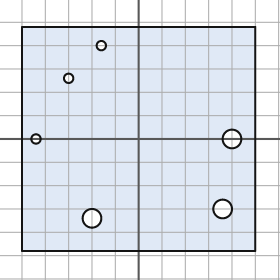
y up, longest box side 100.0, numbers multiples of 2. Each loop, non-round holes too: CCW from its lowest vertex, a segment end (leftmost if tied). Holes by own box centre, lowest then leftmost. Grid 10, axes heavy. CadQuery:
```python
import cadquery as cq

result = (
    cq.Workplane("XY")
    .moveTo(-50.0, -48.0)
    .lineTo(50.0, -48.0)
    .lineTo(50.0, 48.0)
    .lineTo(-50.0, 48.0)
    .close()
    .moveTo(-20.0, -34.0)
    .circle(4.0)
    .moveTo(36.0, -30.0)
    .circle(4.0)
    .moveTo(-44.0, 0.0)
    .circle(2.0)
    .moveTo(40.0, 0.0)
    .circle(4.0)
    .moveTo(-30.0, 26.0)
    .circle(2.0)
    .moveTo(-16.0, 40.0)
    .circle(2.0)
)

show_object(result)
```